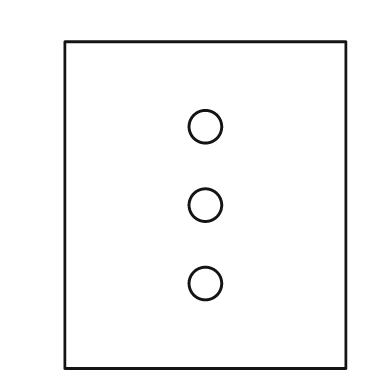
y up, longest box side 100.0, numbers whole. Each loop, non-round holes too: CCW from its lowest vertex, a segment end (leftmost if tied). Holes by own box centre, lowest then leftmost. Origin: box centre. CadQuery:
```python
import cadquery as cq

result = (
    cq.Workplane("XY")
    .moveTo(-43.0, -50.0)
    .lineTo(43.0, -50.0)
    .lineTo(43.0, 50.0)
    .lineTo(-43.0, 50.0)
    .close()
    .moveTo(0.0, -24.0)
    .circle(5.0)
    .moveTo(0.0, 0.0)
    .circle(5.0)
    .moveTo(0.0, 24.0)
    .circle(5.0)
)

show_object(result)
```